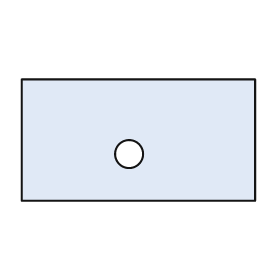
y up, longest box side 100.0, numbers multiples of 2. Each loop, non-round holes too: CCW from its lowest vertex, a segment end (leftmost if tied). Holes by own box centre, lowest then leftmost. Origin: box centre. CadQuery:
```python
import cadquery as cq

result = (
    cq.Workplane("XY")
    .moveTo(-50.0, -26.0)
    .lineTo(50.0, -26.0)
    .lineTo(50.0, 26.0)
    .lineTo(-50.0, 26.0)
    .close()
    .moveTo(-4.0, -6.0)
    .circle(6.0)
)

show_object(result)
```